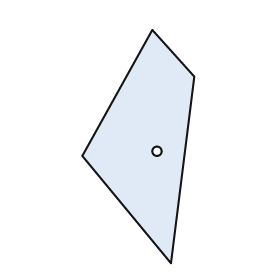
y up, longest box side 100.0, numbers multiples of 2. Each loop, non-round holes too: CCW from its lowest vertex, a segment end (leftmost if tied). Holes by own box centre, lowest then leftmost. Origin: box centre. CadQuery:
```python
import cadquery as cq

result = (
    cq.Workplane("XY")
    .moveTo(14.0, -50.0)
    .lineTo(24.0, 30.0)
    .lineTo(6.0, 50.0)
    .lineTo(-24.0, -4.0)
    .close()
    .moveTo(8.0, -2.0)
    .circle(2.0)
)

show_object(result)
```